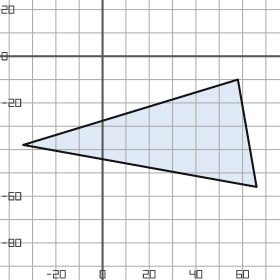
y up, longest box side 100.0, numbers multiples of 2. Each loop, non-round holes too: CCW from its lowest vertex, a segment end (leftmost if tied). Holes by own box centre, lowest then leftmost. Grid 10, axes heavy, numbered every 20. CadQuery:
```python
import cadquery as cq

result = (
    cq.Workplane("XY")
    .moveTo(66.0, -56.0)
    .lineTo(58.0, -10.0)
    .lineTo(-34.0, -38.0)
    .close()
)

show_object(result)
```